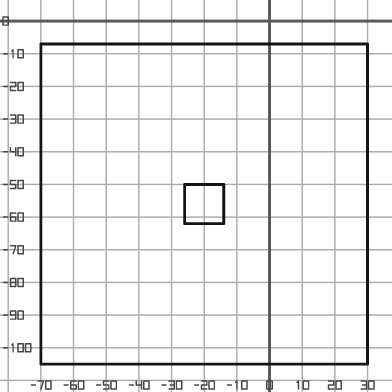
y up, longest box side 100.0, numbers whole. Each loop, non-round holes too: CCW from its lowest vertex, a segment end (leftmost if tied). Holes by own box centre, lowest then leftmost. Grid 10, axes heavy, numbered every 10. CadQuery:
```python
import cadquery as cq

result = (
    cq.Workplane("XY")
    .moveTo(-70.0, -105.0)
    .lineTo(30.0, -105.0)
    .lineTo(30.0, -7.0)
    .lineTo(-70.0, -7.0)
    .close()
    .moveTo(-26.0, -62.0)
    .lineTo(-14.0, -62.0)
    .lineTo(-14.0, -50.0)
    .lineTo(-26.0, -50.0)
    .close()
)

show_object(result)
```